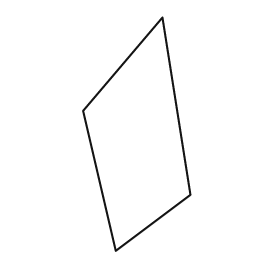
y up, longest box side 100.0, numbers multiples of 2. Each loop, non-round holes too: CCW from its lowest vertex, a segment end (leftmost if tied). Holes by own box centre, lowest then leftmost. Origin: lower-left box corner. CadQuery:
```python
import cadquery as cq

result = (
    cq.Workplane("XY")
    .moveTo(14.0, 0.0)
    .lineTo(46.0, 24.0)
    .lineTo(34.0, 100.0)
    .lineTo(0.0, 60.0)
    .close()
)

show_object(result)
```